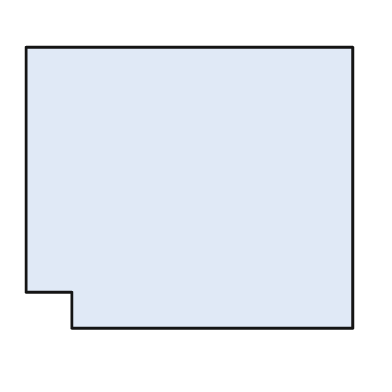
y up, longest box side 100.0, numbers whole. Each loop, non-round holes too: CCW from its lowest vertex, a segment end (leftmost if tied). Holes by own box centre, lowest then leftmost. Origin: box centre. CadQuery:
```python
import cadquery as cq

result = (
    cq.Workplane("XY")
    .moveTo(-36.0, -43.0)
    .lineTo(50.0, -43.0)
    .lineTo(50.0, 43.0)
    .lineTo(-50.0, 43.0)
    .lineTo(-50.0, -32.0)
    .lineTo(-36.0, -32.0)
    .close()
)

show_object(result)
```